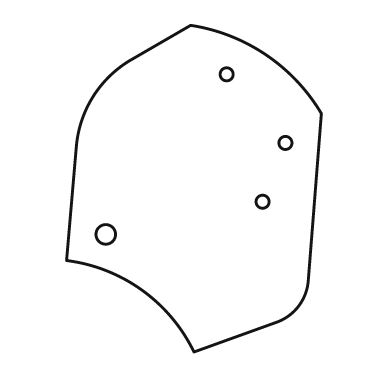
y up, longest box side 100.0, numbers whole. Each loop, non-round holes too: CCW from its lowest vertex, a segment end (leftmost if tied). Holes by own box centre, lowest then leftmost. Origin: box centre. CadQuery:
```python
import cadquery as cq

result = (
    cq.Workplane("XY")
    .moveTo(0.0, -50.0)
    .lineTo(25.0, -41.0)
    .threePointArc((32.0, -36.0), (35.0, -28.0))
    .lineTo(39.0, 23.0)
    .threePointArc((22.0, 41.0), (-1.0, 50.0))
    .lineTo(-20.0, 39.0)
    .threePointArc((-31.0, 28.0), (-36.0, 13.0))
    .lineTo(-39.0, -22.0)
    .threePointArc((-16.0, -31.0), (0.0, -50.0))
    .close()
    .moveTo(-27.0, -14.0)
    .circle(3.0)
    .moveTo(21.0, -4.0)
    .circle(2.0)
    .moveTo(28.0, 14.0)
    .circle(2.0)
    .moveTo(10.0, 35.0)
    .circle(2.0)
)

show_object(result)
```